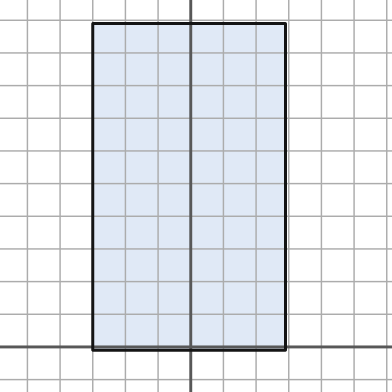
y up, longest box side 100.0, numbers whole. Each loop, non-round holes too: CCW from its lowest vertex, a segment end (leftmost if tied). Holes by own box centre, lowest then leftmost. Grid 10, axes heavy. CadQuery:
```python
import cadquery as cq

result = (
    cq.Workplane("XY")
    .moveTo(-30.0, -1.0)
    .lineTo(29.0, -1.0)
    .lineTo(29.0, 99.0)
    .lineTo(-30.0, 99.0)
    .close()
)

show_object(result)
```